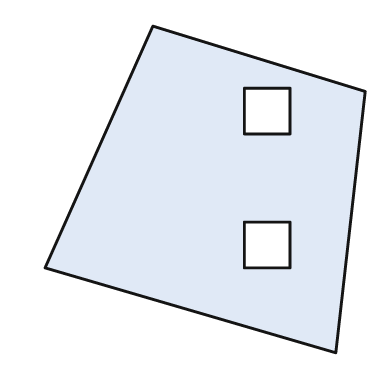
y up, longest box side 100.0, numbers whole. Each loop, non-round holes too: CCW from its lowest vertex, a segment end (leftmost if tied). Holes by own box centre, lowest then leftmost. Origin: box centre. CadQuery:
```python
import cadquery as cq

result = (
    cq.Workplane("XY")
    .moveTo(40.0, -50.0)
    .lineTo(49.0, 30.0)
    .lineTo(-16.0, 50.0)
    .lineTo(-49.0, -24.0)
    .close()
    .moveTo(12.0, -24.0)
    .lineTo(26.0, -24.0)
    .lineTo(26.0, -10.0)
    .lineTo(12.0, -10.0)
    .close()
    .moveTo(12.0, 17.0)
    .lineTo(26.0, 17.0)
    .lineTo(26.0, 31.0)
    .lineTo(12.0, 31.0)
    .close()
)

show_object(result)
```